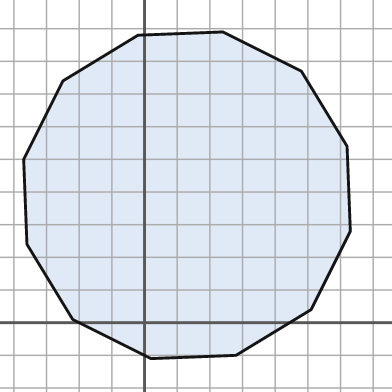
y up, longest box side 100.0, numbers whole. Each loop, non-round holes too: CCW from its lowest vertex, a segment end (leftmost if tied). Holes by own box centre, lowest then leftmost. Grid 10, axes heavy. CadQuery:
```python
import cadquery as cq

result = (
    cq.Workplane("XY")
    .moveTo(2.0, -11.0)
    .lineTo(28.0, -10.0)
    .lineTo(51.0, 4.0)
    .lineTo(63.0, 28.0)
    .lineTo(62.0, 54.0)
    .lineTo(48.0, 77.0)
    .lineTo(24.0, 89.0)
    .lineTo(-2.0, 88.0)
    .lineTo(-25.0, 74.0)
    .lineTo(-37.0, 50.0)
    .lineTo(-36.0, 24.0)
    .lineTo(-22.0, 1.0)
    .close()
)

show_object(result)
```